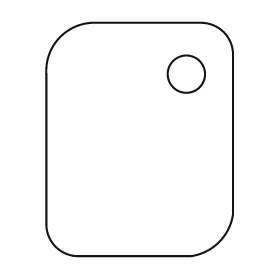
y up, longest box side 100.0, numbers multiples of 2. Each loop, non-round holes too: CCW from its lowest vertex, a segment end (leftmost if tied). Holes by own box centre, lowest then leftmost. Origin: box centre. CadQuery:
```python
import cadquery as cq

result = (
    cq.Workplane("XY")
    .moveTo(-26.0, -50.0)
    .lineTo(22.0, -50.0)
    .threePointArc((34.0, -44.0), (40.0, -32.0))
    .lineTo(40.0, 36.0)
    .threePointArc((36.0, 46.0), (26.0, 50.0))
    .lineTo(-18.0, 50.0)
    .threePointArc((-34.0, 44.0), (-40.0, 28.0))
    .lineTo(-40.0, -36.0)
    .threePointArc((-36.0, -46.0), (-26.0, -50.0))
    .close()
    .moveTo(20.0, 28.0)
    .circle(8.0)
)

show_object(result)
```